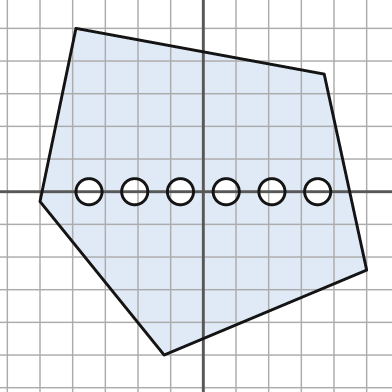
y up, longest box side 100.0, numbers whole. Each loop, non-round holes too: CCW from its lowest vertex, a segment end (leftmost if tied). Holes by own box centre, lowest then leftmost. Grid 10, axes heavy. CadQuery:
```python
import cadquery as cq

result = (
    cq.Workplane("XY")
    .moveTo(-12.0, -50.0)
    .lineTo(50.0, -24.0)
    .lineTo(37.0, 36.0)
    .lineTo(-39.0, 50.0)
    .lineTo(-50.0, -3.0)
    .close()
    .moveTo(-35.0, 0.0)
    .circle(4.0)
    .moveTo(-21.0, 0.0)
    .circle(4.0)
    .moveTo(-7.0, 0.0)
    .circle(4.0)
    .moveTo(7.0, 0.0)
    .circle(4.0)
    .moveTo(21.0, 0.0)
    .circle(4.0)
    .moveTo(35.0, 0.0)
    .circle(4.0)
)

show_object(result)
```